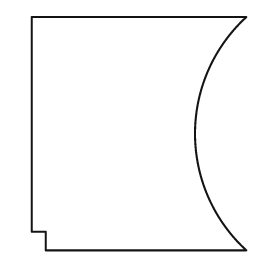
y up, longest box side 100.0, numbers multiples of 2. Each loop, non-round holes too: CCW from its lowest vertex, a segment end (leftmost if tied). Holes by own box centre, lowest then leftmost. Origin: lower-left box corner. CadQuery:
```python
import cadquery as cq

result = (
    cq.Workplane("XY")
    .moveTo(6.0, 0.0)
    .lineTo(92.0, 0.0)
    .threePointArc((70.0, 50.0), (92.0, 100.0))
    .lineTo(0.0, 100.0)
    .lineTo(0.0, 8.0)
    .lineTo(6.0, 8.0)
    .close()
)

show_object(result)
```